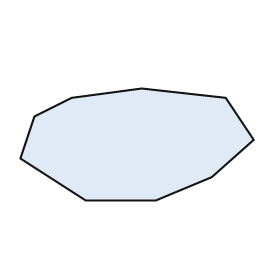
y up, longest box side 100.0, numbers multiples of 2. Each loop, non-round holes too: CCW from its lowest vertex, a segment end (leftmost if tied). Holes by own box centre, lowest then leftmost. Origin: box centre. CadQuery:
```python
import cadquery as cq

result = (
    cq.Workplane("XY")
    .moveTo(-22.0, -24.0)
    .lineTo(8.0, -24.0)
    .lineTo(32.0, -14.0)
    .lineTo(50.0, 2.0)
    .lineTo(38.0, 20.0)
    .lineTo(2.0, 24.0)
    .lineTo(-28.0, 20.0)
    .lineTo(-44.0, 12.0)
    .lineTo(-50.0, -6.0)
    .close()
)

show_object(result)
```